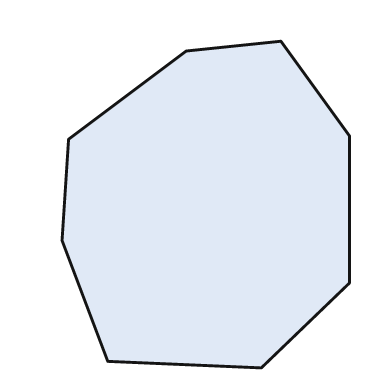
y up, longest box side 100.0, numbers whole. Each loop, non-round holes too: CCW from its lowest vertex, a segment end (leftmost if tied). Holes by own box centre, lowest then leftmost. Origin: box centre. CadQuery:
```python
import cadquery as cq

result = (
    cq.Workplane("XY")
    .moveTo(17.0, -50.0)
    .lineTo(44.0, -24.0)
    .lineTo(44.0, 21.0)
    .lineTo(23.0, 50.0)
    .lineTo(-6.0, 47.0)
    .lineTo(-42.0, 20.0)
    .lineTo(-44.0, -11.0)
    .lineTo(-30.0, -48.0)
    .close()
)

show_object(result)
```